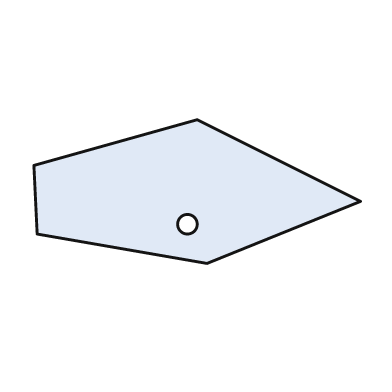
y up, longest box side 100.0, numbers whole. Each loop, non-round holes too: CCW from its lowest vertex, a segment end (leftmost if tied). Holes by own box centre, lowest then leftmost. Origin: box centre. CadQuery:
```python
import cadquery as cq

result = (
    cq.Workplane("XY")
    .moveTo(3.0, -22.0)
    .lineTo(50.0, -3.0)
    .lineTo(0.0, 22.0)
    .lineTo(-50.0, 8.0)
    .lineTo(-49.0, -13.0)
    .close()
    .moveTo(-3.0, -10.0)
    .circle(3.0)
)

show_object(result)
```